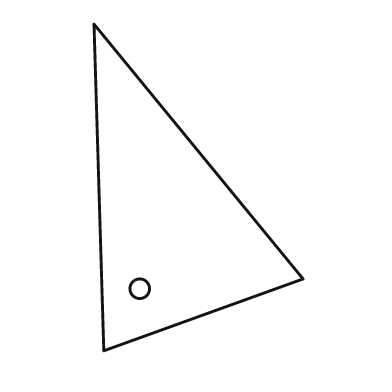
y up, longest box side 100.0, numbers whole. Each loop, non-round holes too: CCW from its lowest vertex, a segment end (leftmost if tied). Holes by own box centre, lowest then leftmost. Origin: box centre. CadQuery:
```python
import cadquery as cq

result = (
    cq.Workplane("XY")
    .moveTo(-29.0, -50.0)
    .lineTo(32.0, -28.0)
    .lineTo(-32.0, 50.0)
    .close()
    .moveTo(-18.0, -31.0)
    .circle(3.0)
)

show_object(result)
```